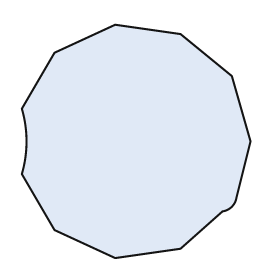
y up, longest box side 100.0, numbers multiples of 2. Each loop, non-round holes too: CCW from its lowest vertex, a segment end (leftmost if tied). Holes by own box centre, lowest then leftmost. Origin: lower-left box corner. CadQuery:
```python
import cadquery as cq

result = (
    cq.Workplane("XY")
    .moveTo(40.0, 0.0)
    .lineTo(68.0, 4.0)
    .lineTo(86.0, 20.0)
    .threePointArc((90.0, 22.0), (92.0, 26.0))
    .lineTo(98.0, 50.0)
    .lineTo(90.0, 78.0)
    .lineTo(68.0, 96.0)
    .lineTo(40.0, 100.0)
    .lineTo(14.0, 88.0)
    .lineTo(0.0, 64.0)
    .threePointArc((2.0, 50.0), (0.0, 36.0))
    .lineTo(14.0, 12.0)
    .close()
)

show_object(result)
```